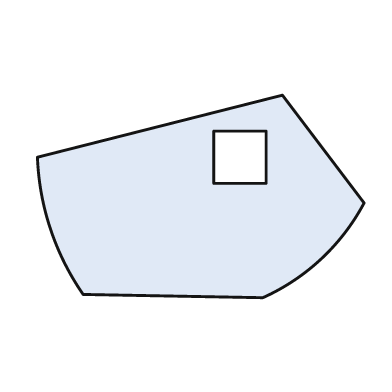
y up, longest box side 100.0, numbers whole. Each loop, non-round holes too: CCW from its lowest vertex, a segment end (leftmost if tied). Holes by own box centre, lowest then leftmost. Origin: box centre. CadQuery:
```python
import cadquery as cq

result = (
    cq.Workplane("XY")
    .moveTo(19.0, -31.0)
    .threePointArc((37.0, -19.0), (50.0, -2.0))
    .lineTo(25.0, 31.0)
    .lineTo(-50.0, 12.0)
    .threePointArc((-46.0, -10.0), (-36.0, -30.0))
    .close()
    .moveTo(4.0, 4.0)
    .lineTo(20.0, 4.0)
    .lineTo(20.0, 20.0)
    .lineTo(4.0, 20.0)
    .close()
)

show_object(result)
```